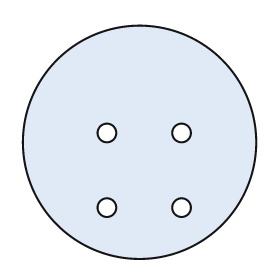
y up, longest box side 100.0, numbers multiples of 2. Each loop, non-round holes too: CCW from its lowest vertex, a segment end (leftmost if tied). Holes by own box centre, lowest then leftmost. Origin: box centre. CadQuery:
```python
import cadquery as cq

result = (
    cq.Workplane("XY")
    .moveTo(0.0, 0.0)
    .circle(50.0)
    .moveTo(-14.0, -28.0)
    .circle(4.0)
    .moveTo(18.0, -28.0)
    .circle(4.0)
    .moveTo(-14.0, 4.0)
    .circle(4.0)
    .moveTo(18.0, 4.0)
    .circle(4.0)
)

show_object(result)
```